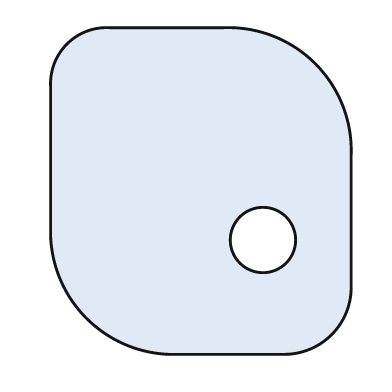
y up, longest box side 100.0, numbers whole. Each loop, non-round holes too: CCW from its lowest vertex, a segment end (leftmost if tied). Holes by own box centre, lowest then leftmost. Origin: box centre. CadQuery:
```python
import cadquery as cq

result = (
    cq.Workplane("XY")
    .moveTo(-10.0, -50.0)
    .lineTo(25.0, -50.0)
    .threePointArc((40.0, -44.0), (46.0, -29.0))
    .lineTo(46.0, 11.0)
    .threePointArc((35.0, 39.0), (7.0, 50.0))
    .lineTo(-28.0, 50.0)
    .threePointArc((-41.0, 45.0), (-46.0, 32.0))
    .lineTo(-46.0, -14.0)
    .threePointArc((-35.0, -39.0), (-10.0, -50.0))
    .close()
    .moveTo(19.0, -15.0)
    .circle(10.0)
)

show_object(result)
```